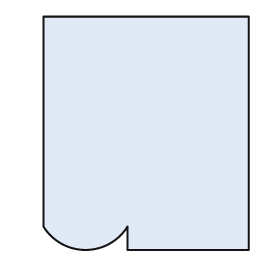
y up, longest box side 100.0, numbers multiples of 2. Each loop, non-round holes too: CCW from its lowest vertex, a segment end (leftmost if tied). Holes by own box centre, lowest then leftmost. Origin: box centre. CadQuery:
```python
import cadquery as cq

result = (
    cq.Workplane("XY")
    .moveTo(-8.0, -50.0)
    .lineTo(44.0, -50.0)
    .lineTo(44.0, 50.0)
    .lineTo(-44.0, 50.0)
    .lineTo(-44.0, -40.0)
    .threePointArc((-26.0, -50.0), (-8.0, -40.0))
    .close()
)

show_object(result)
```